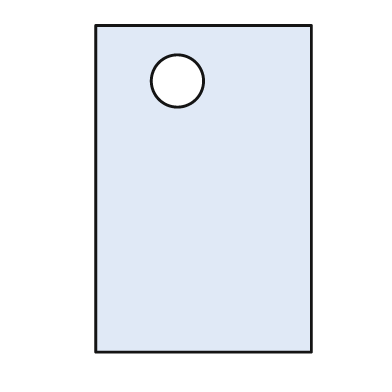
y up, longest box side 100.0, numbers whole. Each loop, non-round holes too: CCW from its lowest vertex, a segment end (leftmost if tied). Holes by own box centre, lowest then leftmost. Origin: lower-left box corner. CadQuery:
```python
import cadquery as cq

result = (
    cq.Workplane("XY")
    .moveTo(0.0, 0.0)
    .lineTo(66.0, 0.0)
    .lineTo(66.0, 100.0)
    .lineTo(0.0, 100.0)
    .close()
    .moveTo(25.0, 83.0)
    .circle(8.0)
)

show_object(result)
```